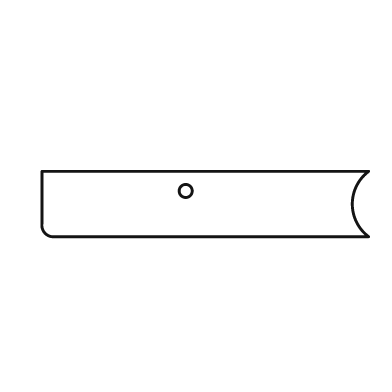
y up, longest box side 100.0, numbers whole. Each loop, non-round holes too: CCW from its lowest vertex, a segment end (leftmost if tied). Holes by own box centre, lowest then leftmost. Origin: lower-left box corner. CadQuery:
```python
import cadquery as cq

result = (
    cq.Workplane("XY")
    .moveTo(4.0, 0.0)
    .lineTo(100.0, 0.0)
    .threePointArc((95.0, 10.0), (100.0, 20.0))
    .lineTo(0.0, 20.0)
    .lineTo(0.0, 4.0)
    .threePointArc((1.0, 1.0), (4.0, 0.0))
    .close()
    .moveTo(44.0, 14.0)
    .circle(2.0)
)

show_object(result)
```